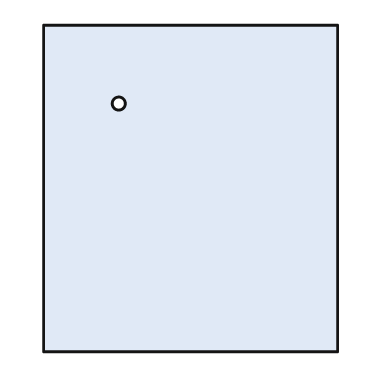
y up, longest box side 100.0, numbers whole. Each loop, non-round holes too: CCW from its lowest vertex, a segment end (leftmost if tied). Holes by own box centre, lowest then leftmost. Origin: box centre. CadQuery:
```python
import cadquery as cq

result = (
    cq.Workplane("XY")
    .moveTo(-45.0, -50.0)
    .lineTo(45.0, -50.0)
    .lineTo(45.0, 50.0)
    .lineTo(-45.0, 50.0)
    .close()
    .moveTo(-22.0, 26.0)
    .circle(2.0)
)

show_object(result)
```